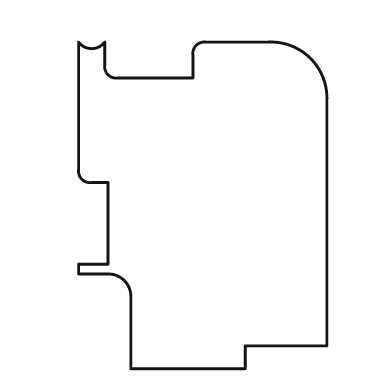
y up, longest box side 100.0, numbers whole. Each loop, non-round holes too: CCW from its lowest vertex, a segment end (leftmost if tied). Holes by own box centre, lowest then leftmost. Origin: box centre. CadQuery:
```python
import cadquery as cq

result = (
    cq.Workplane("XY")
    .moveTo(-22.0, -50.0)
    .lineTo(13.0, -50.0)
    .lineTo(13.0, -43.0)
    .lineTo(38.0, -43.0)
    .lineTo(38.0, 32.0)
    .threePointArc((33.0, 45.0), (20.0, 50.0))
    .lineTo(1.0, 50.0)
    .threePointArc((-2.0, 49.0), (-3.0, 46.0))
    .lineTo(-3.0, 39.0)
    .lineTo(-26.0, 39.0)
    .threePointArc((-29.0, 40.0), (-30.0, 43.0))
    .lineTo(-30.0, 50.0)
    .threePointArc((-34.0, 48.0), (-38.0, 50.0))
    .lineTo(-38.0, 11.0)
    .threePointArc((-37.0, 8.0), (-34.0, 7.0))
    .lineTo(-29.0, 7.0)
    .lineTo(-29.0, -18.0)
    .lineTo(-38.0, -18.0)
    .lineTo(-38.0, -21.0)
    .lineTo(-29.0, -21.0)
    .threePointArc((-24.0, -23.0), (-22.0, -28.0))
    .close()
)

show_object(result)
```